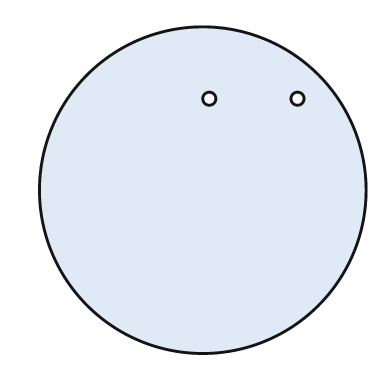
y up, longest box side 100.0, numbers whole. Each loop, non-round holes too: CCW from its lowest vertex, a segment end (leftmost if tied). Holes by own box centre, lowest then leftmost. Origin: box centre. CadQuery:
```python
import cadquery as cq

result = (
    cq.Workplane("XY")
    .moveTo(0.0, 0.0)
    .circle(50.0)
    .moveTo(2.0, 28.0)
    .circle(2.0)
    .moveTo(29.0, 28.0)
    .circle(2.0)
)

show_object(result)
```